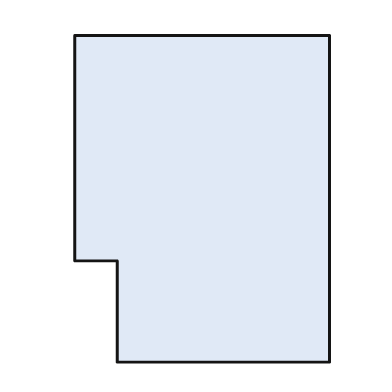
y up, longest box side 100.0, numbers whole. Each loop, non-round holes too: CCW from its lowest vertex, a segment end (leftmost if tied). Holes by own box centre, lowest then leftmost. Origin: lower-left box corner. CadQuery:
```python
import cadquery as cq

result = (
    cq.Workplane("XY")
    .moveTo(13.0, 0.0)
    .lineTo(78.0, 0.0)
    .lineTo(78.0, 100.0)
    .lineTo(0.0, 100.0)
    .lineTo(0.0, 31.0)
    .lineTo(13.0, 31.0)
    .close()
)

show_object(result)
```